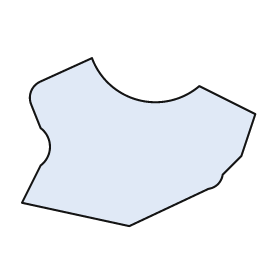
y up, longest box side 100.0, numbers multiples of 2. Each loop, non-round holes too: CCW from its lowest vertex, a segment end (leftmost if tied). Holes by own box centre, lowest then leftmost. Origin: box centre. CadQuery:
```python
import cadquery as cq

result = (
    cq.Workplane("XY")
    .moveTo(-4.0, -36.0)
    .lineTo(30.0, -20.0)
    .threePointArc((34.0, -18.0), (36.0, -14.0))
    .lineTo(44.0, -6.0)
    .lineTo(50.0, 12.0)
    .lineTo(26.0, 24.0)
    .threePointArc((0.0, 18.0), (-20.0, 36.0))
    .lineTo(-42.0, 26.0)
    .threePointArc((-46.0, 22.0), (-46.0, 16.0))
    .lineTo(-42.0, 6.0)
    .threePointArc((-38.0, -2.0), (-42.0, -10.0))
    .lineTo(-50.0, -26.0)
    .close()
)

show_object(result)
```